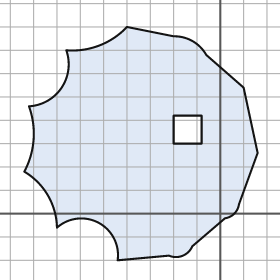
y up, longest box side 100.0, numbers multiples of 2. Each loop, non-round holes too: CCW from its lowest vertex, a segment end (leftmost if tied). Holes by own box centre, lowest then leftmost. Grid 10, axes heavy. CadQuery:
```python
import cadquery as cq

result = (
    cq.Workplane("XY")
    .moveTo(-44.0, -20.0)
    .lineTo(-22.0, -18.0)
    .threePointArc((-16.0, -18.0), (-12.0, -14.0))
    .lineTo(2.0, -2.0)
    .threePointArc((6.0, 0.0), (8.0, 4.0))
    .lineTo(16.0, 26.0)
    .lineTo(10.0, 54.0)
    .lineTo(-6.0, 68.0)
    .threePointArc((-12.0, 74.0), (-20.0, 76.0))
    .lineTo(-40.0, 80.0)
    .threePointArc((-52.0, 72.0), (-66.0, 70.0))
    .threePointArc((-68.0, 54.0), (-82.0, 46.0))
    .threePointArc((-80.0, 32.0), (-84.0, 18.0))
    .threePointArc((-74.0, 8.0), (-70.0, -6.0))
    .threePointArc((-52.0, -4.0), (-44.0, -20.0))
    .close()
    .moveTo(-20.0, 30.0)
    .lineTo(-8.0, 30.0)
    .lineTo(-8.0, 42.0)
    .lineTo(-20.0, 42.0)
    .close()
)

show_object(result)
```